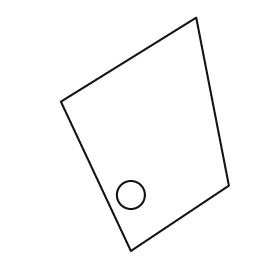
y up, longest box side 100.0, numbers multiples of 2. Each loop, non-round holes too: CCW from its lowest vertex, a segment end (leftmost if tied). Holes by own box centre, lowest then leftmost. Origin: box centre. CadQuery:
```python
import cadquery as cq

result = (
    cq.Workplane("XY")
    .moveTo(-6.0, -50.0)
    .lineTo(36.0, -22.0)
    .lineTo(22.0, 50.0)
    .lineTo(-36.0, 14.0)
    .close()
    .moveTo(-6.0, -26.0)
    .circle(6.0)
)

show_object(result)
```